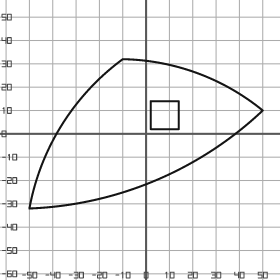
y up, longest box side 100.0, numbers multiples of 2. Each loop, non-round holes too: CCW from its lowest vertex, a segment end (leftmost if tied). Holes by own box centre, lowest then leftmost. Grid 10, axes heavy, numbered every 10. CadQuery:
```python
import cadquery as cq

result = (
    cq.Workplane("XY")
    .moveTo(-50.0, -32.0)
    .threePointArc((4.0, -20.0), (50.0, 10.0))
    .threePointArc((22.0, 26.0), (-10.0, 32.0))
    .threePointArc((-36.0, 4.0), (-50.0, -32.0))
    .close()
    .moveTo(2.0, 2.0)
    .lineTo(14.0, 2.0)
    .lineTo(14.0, 14.0)
    .lineTo(2.0, 14.0)
    .close()
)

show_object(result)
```